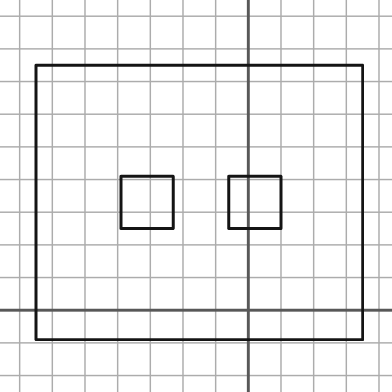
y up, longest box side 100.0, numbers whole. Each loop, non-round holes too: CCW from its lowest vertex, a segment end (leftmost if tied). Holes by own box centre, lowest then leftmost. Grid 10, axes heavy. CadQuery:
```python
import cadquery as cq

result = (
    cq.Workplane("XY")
    .moveTo(-65.0, -9.0)
    .lineTo(35.0, -9.0)
    .lineTo(35.0, 75.0)
    .lineTo(-65.0, 75.0)
    .close()
    .moveTo(-39.0, 25.0)
    .lineTo(-23.0, 25.0)
    .lineTo(-23.0, 41.0)
    .lineTo(-39.0, 41.0)
    .close()
    .moveTo(-6.0, 25.0)
    .lineTo(10.0, 25.0)
    .lineTo(10.0, 41.0)
    .lineTo(-6.0, 41.0)
    .close()
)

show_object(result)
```